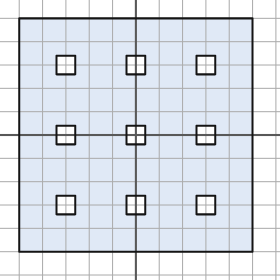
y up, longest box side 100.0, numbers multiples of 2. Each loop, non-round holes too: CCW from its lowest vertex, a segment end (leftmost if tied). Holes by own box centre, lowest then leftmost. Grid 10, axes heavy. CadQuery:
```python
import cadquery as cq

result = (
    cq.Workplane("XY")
    .moveTo(-50.0, -50.0)
    .lineTo(50.0, -50.0)
    .lineTo(50.0, 50.0)
    .lineTo(-50.0, 50.0)
    .close()
    .moveTo(-34.0, -34.0)
    .lineTo(-26.0, -34.0)
    .lineTo(-26.0, -26.0)
    .lineTo(-34.0, -26.0)
    .close()
    .moveTo(-4.0, -34.0)
    .lineTo(4.0, -34.0)
    .lineTo(4.0, -26.0)
    .lineTo(-4.0, -26.0)
    .close()
    .moveTo(26.0, -34.0)
    .lineTo(34.0, -34.0)
    .lineTo(34.0, -26.0)
    .lineTo(26.0, -26.0)
    .close()
    .moveTo(-34.0, -4.0)
    .lineTo(-26.0, -4.0)
    .lineTo(-26.0, 4.0)
    .lineTo(-34.0, 4.0)
    .close()
    .moveTo(-4.0, -4.0)
    .lineTo(4.0, -4.0)
    .lineTo(4.0, 4.0)
    .lineTo(-4.0, 4.0)
    .close()
    .moveTo(26.0, -4.0)
    .lineTo(34.0, -4.0)
    .lineTo(34.0, 4.0)
    .lineTo(26.0, 4.0)
    .close()
    .moveTo(-34.0, 26.0)
    .lineTo(-26.0, 26.0)
    .lineTo(-26.0, 34.0)
    .lineTo(-34.0, 34.0)
    .close()
    .moveTo(-4.0, 26.0)
    .lineTo(4.0, 26.0)
    .lineTo(4.0, 34.0)
    .lineTo(-4.0, 34.0)
    .close()
    .moveTo(26.0, 26.0)
    .lineTo(34.0, 26.0)
    .lineTo(34.0, 34.0)
    .lineTo(26.0, 34.0)
    .close()
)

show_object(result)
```